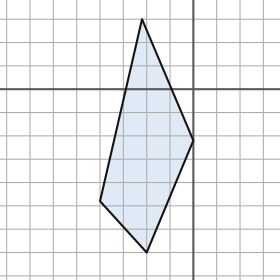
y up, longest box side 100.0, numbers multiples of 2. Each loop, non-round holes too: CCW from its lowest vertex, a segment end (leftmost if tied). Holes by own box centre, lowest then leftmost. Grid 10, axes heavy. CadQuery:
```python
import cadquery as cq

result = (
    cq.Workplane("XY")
    .moveTo(-20.0, -70.0)
    .lineTo(0.0, -22.0)
    .lineTo(-22.0, 30.0)
    .lineTo(-40.0, -48.0)
    .close()
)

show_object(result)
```